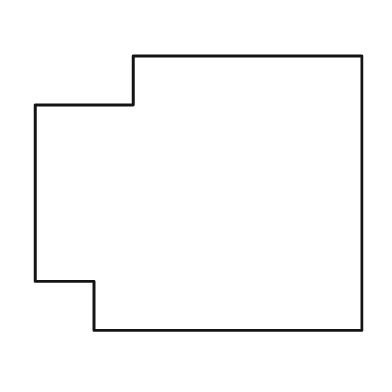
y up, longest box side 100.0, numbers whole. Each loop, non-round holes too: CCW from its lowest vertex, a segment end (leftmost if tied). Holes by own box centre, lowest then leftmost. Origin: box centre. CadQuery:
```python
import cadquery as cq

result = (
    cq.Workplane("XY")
    .moveTo(-32.0, -42.0)
    .lineTo(50.0, -42.0)
    .lineTo(50.0, 42.0)
    .lineTo(-20.0, 42.0)
    .lineTo(-20.0, 27.0)
    .lineTo(-50.0, 27.0)
    .lineTo(-50.0, -27.0)
    .lineTo(-32.0, -27.0)
    .close()
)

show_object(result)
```